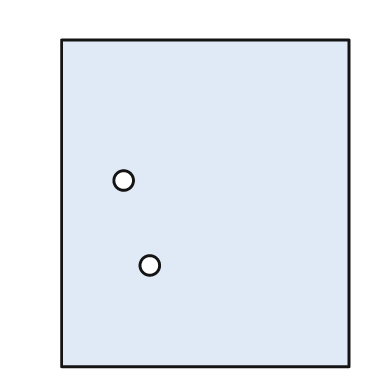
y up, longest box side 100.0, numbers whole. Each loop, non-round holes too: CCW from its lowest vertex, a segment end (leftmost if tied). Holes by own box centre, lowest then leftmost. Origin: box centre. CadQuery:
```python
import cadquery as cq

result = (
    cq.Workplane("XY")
    .moveTo(-44.0, -50.0)
    .lineTo(44.0, -50.0)
    .lineTo(44.0, 50.0)
    .lineTo(-44.0, 50.0)
    .close()
    .moveTo(-17.0, -19.0)
    .circle(3.0)
    .moveTo(-25.0, 7.0)
    .circle(3.0)
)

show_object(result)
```